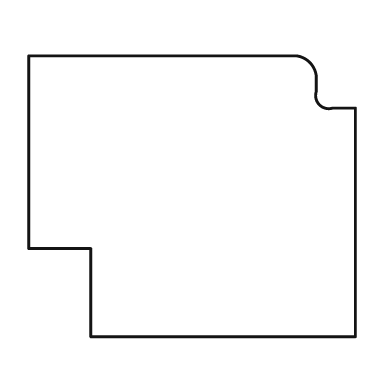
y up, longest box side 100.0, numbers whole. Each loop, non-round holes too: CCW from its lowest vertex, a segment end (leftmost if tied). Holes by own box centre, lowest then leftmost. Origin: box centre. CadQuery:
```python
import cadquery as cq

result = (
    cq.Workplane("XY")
    .moveTo(-31.0, -43.0)
    .lineTo(50.0, -43.0)
    .lineTo(50.0, 27.0)
    .lineTo(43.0, 27.0)
    .threePointArc((39.0, 28.0), (38.0, 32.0))
    .lineTo(38.0, 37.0)
    .threePointArc((36.0, 41.0), (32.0, 43.0))
    .lineTo(-50.0, 43.0)
    .lineTo(-50.0, -16.0)
    .lineTo(-31.0, -16.0)
    .close()
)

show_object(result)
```